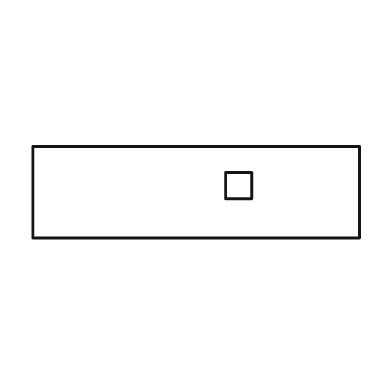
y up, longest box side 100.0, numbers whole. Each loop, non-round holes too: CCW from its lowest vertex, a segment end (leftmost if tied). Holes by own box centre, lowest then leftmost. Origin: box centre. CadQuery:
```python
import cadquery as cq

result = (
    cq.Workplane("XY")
    .moveTo(-50.0, -14.0)
    .lineTo(50.0, -14.0)
    .lineTo(50.0, 14.0)
    .lineTo(-50.0, 14.0)
    .close()
    .moveTo(9.0, -2.0)
    .lineTo(17.0, -2.0)
    .lineTo(17.0, 6.0)
    .lineTo(9.0, 6.0)
    .close()
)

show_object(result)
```